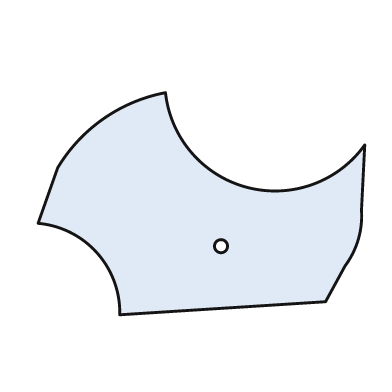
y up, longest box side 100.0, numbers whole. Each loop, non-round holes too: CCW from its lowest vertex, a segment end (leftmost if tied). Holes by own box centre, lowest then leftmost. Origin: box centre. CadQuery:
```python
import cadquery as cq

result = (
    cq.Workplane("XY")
    .moveTo(-25.0, -34.0)
    .lineTo(38.0, -30.0)
    .lineTo(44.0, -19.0)
    .threePointArc((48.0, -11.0), (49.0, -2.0))
    .lineTo(50.0, 18.0)
    .threePointArc((14.0, 5.0), (-11.0, 34.0))
    .threePointArc((-30.0, 26.0), (-44.0, 11.0))
    .lineTo(-50.0, -6.0)
    .threePointArc((-32.0, -15.0), (-25.0, -34.0))
    .close()
    .moveTo(6.0, -13.0)
    .circle(2.0)
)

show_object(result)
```